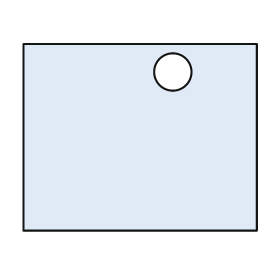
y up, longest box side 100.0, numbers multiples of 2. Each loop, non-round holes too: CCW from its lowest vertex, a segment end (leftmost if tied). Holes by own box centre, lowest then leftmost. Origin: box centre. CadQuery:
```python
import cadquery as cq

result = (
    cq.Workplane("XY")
    .moveTo(-50.0, -40.0)
    .lineTo(50.0, -40.0)
    .lineTo(50.0, 40.0)
    .lineTo(-50.0, 40.0)
    .close()
    .moveTo(14.0, 28.0)
    .circle(8.0)
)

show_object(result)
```